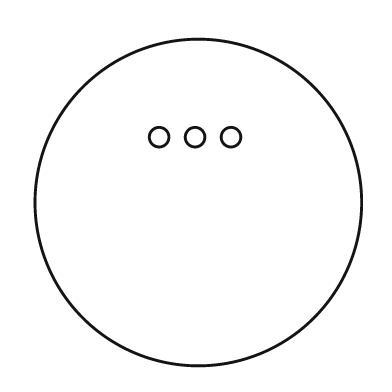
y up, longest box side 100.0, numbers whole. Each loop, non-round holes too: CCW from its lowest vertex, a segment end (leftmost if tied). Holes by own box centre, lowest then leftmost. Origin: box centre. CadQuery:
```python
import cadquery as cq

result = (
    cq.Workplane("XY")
    .moveTo(0.0, 0.0)
    .circle(50.0)
    .moveTo(-12.0, 20.0)
    .circle(3.0)
    .moveTo(-1.0, 20.0)
    .circle(3.0)
    .moveTo(10.0, 20.0)
    .circle(3.0)
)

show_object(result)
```